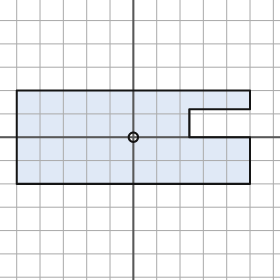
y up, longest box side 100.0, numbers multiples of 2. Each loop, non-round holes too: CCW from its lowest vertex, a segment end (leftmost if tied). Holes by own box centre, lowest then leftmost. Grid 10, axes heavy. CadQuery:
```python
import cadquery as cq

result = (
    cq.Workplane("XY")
    .moveTo(-50.0, -20.0)
    .lineTo(50.0, -20.0)
    .lineTo(50.0, 0.0)
    .lineTo(24.0, 0.0)
    .lineTo(24.0, 12.0)
    .lineTo(50.0, 12.0)
    .lineTo(50.0, 20.0)
    .lineTo(-50.0, 20.0)
    .close()
    .moveTo(0.0, 0.0)
    .circle(2.0)
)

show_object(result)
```